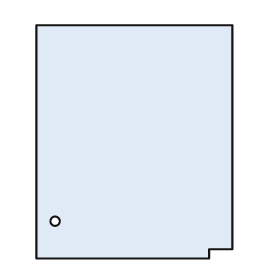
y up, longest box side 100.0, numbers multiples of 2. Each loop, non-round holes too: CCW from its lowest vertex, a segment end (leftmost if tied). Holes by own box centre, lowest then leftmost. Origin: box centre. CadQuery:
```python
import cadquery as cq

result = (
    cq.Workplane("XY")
    .moveTo(-42.0, -50.0)
    .lineTo(32.0, -50.0)
    .lineTo(32.0, -46.0)
    .lineTo(42.0, -46.0)
    .lineTo(42.0, 50.0)
    .lineTo(-42.0, 50.0)
    .close()
    .moveTo(-34.0, -34.0)
    .circle(2.0)
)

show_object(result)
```